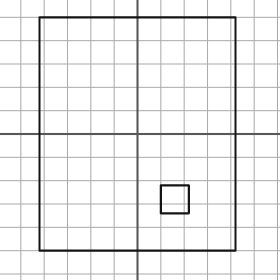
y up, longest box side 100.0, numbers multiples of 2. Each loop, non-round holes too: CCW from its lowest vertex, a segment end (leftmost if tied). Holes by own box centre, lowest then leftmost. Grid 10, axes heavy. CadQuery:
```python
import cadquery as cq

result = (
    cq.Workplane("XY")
    .moveTo(-42.0, -50.0)
    .lineTo(42.0, -50.0)
    .lineTo(42.0, 50.0)
    .lineTo(-42.0, 50.0)
    .close()
    .moveTo(10.0, -34.0)
    .lineTo(22.0, -34.0)
    .lineTo(22.0, -22.0)
    .lineTo(10.0, -22.0)
    .close()
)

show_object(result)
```